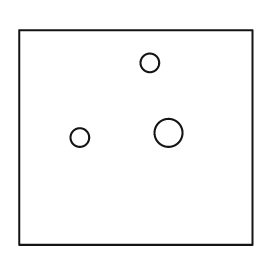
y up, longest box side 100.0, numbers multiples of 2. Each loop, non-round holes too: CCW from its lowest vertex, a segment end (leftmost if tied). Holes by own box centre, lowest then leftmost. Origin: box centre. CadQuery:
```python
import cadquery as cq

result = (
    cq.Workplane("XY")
    .moveTo(-50.0, -46.0)
    .lineTo(50.0, -46.0)
    .lineTo(50.0, 46.0)
    .lineTo(-50.0, 46.0)
    .close()
    .moveTo(-24.0, 0.0)
    .circle(4.0)
    .moveTo(14.0, 2.0)
    .circle(6.0)
    .moveTo(6.0, 32.0)
    .circle(4.0)
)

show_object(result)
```